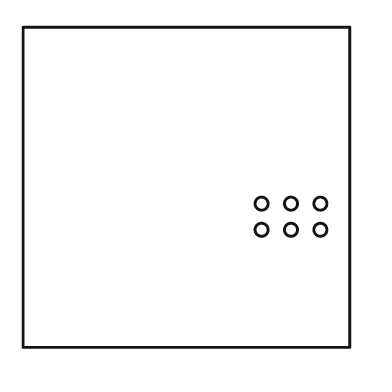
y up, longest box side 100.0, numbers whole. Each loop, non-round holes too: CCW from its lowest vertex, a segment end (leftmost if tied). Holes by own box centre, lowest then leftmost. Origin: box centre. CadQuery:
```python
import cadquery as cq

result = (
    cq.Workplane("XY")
    .moveTo(-50.0, -49.0)
    .lineTo(50.0, -49.0)
    .lineTo(50.0, 49.0)
    .lineTo(-50.0, 49.0)
    .close()
    .moveTo(23.0, -13.0)
    .circle(2.0)
    .moveTo(32.0, -13.0)
    .circle(2.0)
    .moveTo(41.0, -13.0)
    .circle(2.0)
    .moveTo(23.0, -5.0)
    .circle(2.0)
    .moveTo(32.0, -5.0)
    .circle(2.0)
    .moveTo(41.0, -5.0)
    .circle(2.0)
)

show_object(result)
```